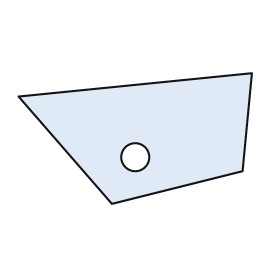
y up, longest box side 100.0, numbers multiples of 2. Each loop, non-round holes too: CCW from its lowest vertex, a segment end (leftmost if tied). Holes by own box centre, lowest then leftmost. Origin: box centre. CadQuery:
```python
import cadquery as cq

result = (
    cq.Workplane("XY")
    .moveTo(-10.0, -28.0)
    .lineTo(46.0, -14.0)
    .lineTo(50.0, 28.0)
    .lineTo(-50.0, 18.0)
    .close()
    .moveTo(0.0, -8.0)
    .circle(6.0)
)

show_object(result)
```